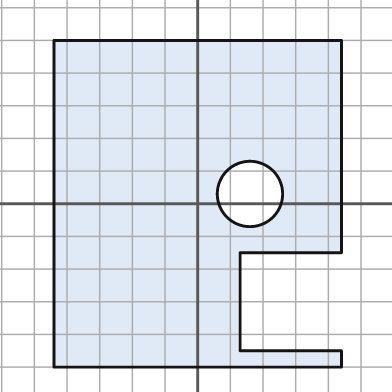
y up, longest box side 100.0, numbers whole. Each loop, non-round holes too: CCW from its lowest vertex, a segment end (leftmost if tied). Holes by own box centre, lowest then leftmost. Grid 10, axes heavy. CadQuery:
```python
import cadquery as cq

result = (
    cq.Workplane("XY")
    .moveTo(-44.0, -50.0)
    .lineTo(44.0, -50.0)
    .lineTo(44.0, -45.0)
    .lineTo(13.0, -45.0)
    .lineTo(13.0, -15.0)
    .lineTo(44.0, -15.0)
    .lineTo(44.0, 50.0)
    .lineTo(-44.0, 50.0)
    .close()
    .moveTo(16.0, 3.0)
    .circle(10.0)
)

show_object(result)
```